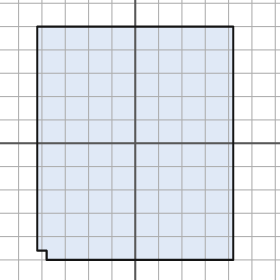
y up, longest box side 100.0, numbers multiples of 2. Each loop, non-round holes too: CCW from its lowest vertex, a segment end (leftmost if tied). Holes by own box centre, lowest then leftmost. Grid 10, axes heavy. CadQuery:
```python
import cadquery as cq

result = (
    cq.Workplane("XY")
    .moveTo(-38.0, -50.0)
    .lineTo(42.0, -50.0)
    .lineTo(42.0, 50.0)
    .lineTo(-42.0, 50.0)
    .lineTo(-42.0, -46.0)
    .lineTo(-38.0, -46.0)
    .close()
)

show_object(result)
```